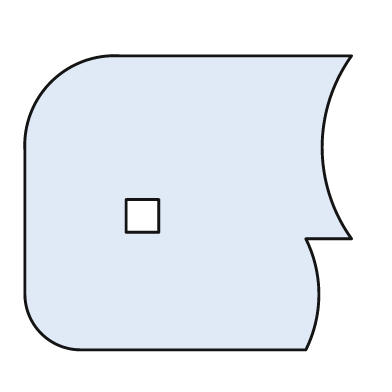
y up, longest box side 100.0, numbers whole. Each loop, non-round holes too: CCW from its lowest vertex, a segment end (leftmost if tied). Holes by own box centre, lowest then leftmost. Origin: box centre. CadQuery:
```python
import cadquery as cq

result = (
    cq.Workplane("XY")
    .moveTo(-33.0, -45.0)
    .lineTo(36.0, -45.0)
    .threePointArc((40.0, -28.0), (36.0, -11.0))
    .lineTo(50.0, -11.0)
    .threePointArc((41.0, 17.0), (50.0, 45.0))
    .lineTo(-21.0, 45.0)
    .threePointArc((-42.0, 37.0), (-50.0, 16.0))
    .lineTo(-50.0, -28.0)
    .threePointArc((-45.0, -40.0), (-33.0, -45.0))
    .close()
    .moveTo(-19.0, -9.0)
    .lineTo(-9.0, -9.0)
    .lineTo(-9.0, 1.0)
    .lineTo(-19.0, 1.0)
    .close()
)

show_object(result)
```